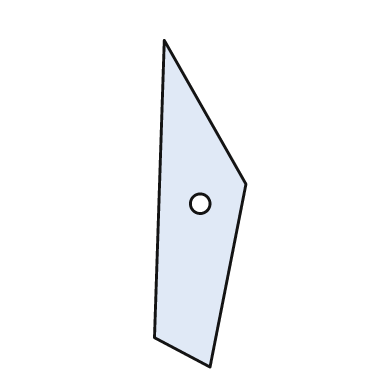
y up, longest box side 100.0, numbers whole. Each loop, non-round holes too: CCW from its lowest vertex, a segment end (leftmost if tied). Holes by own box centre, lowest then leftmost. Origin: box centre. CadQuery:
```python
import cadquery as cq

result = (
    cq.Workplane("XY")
    .moveTo(3.0, -50.0)
    .lineTo(14.0, 6.0)
    .lineTo(-11.0, 50.0)
    .lineTo(-14.0, -41.0)
    .close()
    .moveTo(0.0, 0.0)
    .circle(3.0)
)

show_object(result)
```